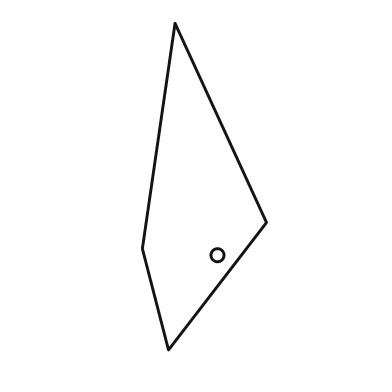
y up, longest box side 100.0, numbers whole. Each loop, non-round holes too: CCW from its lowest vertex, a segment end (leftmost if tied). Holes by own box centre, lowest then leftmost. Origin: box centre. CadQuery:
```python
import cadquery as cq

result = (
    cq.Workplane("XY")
    .moveTo(-11.0, -50.0)
    .lineTo(19.0, -11.0)
    .lineTo(-9.0, 50.0)
    .lineTo(-19.0, -19.0)
    .close()
    .moveTo(4.0, -21.0)
    .circle(2.0)
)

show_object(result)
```